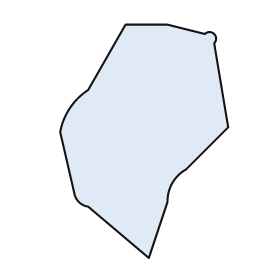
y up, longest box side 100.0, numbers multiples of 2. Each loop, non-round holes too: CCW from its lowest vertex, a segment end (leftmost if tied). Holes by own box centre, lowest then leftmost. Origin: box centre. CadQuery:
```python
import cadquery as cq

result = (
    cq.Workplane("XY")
    .moveTo(2.0, -50.0)
    .lineTo(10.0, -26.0)
    .threePointArc((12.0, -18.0), (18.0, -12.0))
    .lineTo(36.0, 6.0)
    .lineTo(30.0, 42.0)
    .threePointArc((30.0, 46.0), (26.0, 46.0))
    .lineTo(10.0, 50.0)
    .lineTo(-8.0, 50.0)
    .lineTo(-24.0, 22.0)
    .threePointArc((-32.0, 14.0), (-36.0, 4.0))
    .lineTo(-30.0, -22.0)
    .threePointArc((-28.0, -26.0), (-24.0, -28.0))
    .close()
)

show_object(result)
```